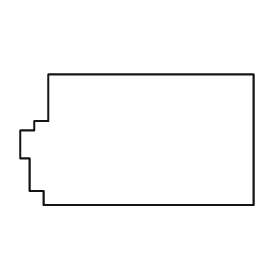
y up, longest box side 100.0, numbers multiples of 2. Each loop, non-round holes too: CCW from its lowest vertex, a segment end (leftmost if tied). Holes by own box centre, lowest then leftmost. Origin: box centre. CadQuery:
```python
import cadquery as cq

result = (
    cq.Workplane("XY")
    .moveTo(-40.0, -28.0)
    .lineTo(50.0, -28.0)
    .lineTo(50.0, 28.0)
    .lineTo(-38.0, 28.0)
    .lineTo(-38.0, 8.0)
    .lineTo(-44.0, 8.0)
    .lineTo(-44.0, 4.0)
    .lineTo(-50.0, 4.0)
    .lineTo(-50.0, -8.0)
    .lineTo(-46.0, -8.0)
    .lineTo(-46.0, -22.0)
    .lineTo(-40.0, -22.0)
    .close()
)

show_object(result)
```